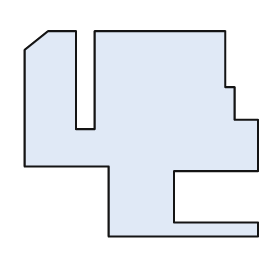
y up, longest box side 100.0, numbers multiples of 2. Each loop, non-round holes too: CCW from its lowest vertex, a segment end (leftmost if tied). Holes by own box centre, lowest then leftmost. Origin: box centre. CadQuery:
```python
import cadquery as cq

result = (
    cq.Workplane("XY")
    .moveTo(-14.0, -44.0)
    .lineTo(50.0, -44.0)
    .lineTo(50.0, -38.0)
    .lineTo(14.0, -38.0)
    .lineTo(14.0, -16.0)
    .lineTo(50.0, -16.0)
    .lineTo(50.0, 6.0)
    .lineTo(40.0, 6.0)
    .lineTo(40.0, 20.0)
    .lineTo(36.0, 20.0)
    .lineTo(36.0, 44.0)
    .lineTo(-20.0, 44.0)
    .lineTo(-20.0, 2.0)
    .lineTo(-28.0, 2.0)
    .lineTo(-28.0, 44.0)
    .lineTo(-40.0, 44.0)
    .lineTo(-50.0, 36.0)
    .lineTo(-50.0, -14.0)
    .lineTo(-14.0, -14.0)
    .close()
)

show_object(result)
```